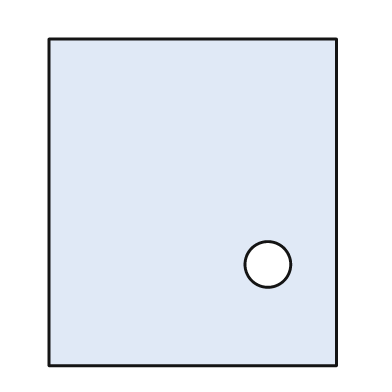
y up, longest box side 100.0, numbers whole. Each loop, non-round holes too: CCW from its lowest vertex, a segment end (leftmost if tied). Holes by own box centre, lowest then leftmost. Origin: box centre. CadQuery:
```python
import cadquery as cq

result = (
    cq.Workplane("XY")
    .moveTo(-44.0, -50.0)
    .lineTo(44.0, -50.0)
    .lineTo(44.0, 50.0)
    .lineTo(-44.0, 50.0)
    .close()
    .moveTo(23.0, -19.0)
    .circle(7.0)
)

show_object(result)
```